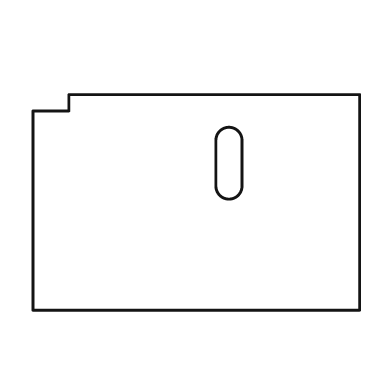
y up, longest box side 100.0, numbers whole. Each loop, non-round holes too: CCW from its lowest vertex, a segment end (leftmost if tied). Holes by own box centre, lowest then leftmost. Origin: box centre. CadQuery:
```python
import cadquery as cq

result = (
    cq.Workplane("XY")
    .moveTo(-50.0, -33.0)
    .lineTo(50.0, -33.0)
    .lineTo(50.0, 33.0)
    .lineTo(-39.0, 33.0)
    .lineTo(-39.0, 28.0)
    .lineTo(-50.0, 28.0)
    .close()
    .moveTo(6.0, 5.0)
    .threePointArc((10.0, 1.0), (14.0, 5.0))
    .lineTo(14.0, 19.0)
    .threePointArc((10.0, 23.0), (6.0, 19.0))
    .close()
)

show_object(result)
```